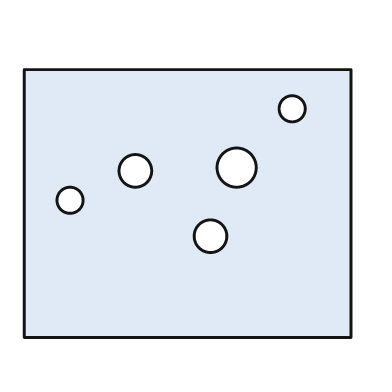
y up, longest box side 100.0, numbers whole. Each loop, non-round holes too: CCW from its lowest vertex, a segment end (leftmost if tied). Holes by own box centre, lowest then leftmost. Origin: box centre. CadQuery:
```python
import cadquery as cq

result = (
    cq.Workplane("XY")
    .moveTo(-50.0, -41.0)
    .lineTo(50.0, -41.0)
    .lineTo(50.0, 41.0)
    .lineTo(-50.0, 41.0)
    .close()
    .moveTo(7.0, -10.0)
    .circle(5.0)
    .moveTo(-36.0, 1.0)
    .circle(4.0)
    .moveTo(-16.0, 10.0)
    .circle(5.0)
    .moveTo(15.0, 11.0)
    .circle(6.0)
    .moveTo(32.0, 29.0)
    .circle(4.0)
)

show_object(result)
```